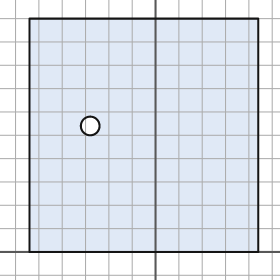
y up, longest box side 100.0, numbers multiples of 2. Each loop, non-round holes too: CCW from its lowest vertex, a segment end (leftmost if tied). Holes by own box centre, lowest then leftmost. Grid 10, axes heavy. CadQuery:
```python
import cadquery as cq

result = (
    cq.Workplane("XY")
    .moveTo(-54.0, 0.0)
    .lineTo(44.0, 0.0)
    .lineTo(44.0, 100.0)
    .lineTo(-54.0, 100.0)
    .close()
    .moveTo(-28.0, 54.0)
    .circle(4.0)
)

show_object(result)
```